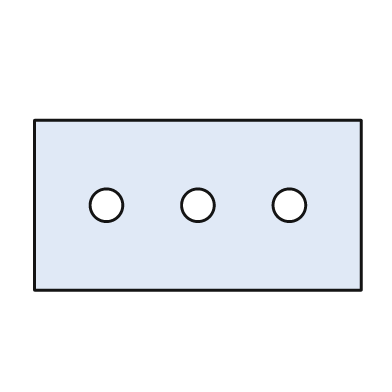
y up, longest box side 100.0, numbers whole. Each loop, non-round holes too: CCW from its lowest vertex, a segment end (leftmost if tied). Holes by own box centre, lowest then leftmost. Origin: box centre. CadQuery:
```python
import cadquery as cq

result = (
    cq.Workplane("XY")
    .moveTo(-50.0, -26.0)
    .lineTo(50.0, -26.0)
    .lineTo(50.0, 26.0)
    .lineTo(-50.0, 26.0)
    .close()
    .moveTo(-28.0, 0.0)
    .circle(5.0)
    .moveTo(0.0, 0.0)
    .circle(5.0)
    .moveTo(28.0, 0.0)
    .circle(5.0)
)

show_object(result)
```